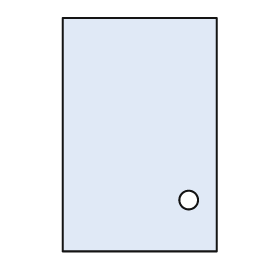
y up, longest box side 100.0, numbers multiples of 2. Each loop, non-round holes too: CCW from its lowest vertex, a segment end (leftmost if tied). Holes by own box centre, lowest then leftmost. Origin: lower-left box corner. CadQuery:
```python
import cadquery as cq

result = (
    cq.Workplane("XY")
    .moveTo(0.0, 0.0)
    .lineTo(66.0, 0.0)
    .lineTo(66.0, 100.0)
    .lineTo(0.0, 100.0)
    .close()
    .moveTo(54.0, 22.0)
    .circle(4.0)
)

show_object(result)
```